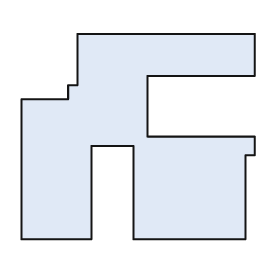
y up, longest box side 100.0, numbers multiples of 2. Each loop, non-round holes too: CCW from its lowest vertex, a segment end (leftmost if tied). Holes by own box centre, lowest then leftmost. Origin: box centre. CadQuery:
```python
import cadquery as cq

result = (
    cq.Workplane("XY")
    .moveTo(-50.0, -44.0)
    .lineTo(-20.0, -44.0)
    .lineTo(-20.0, -4.0)
    .lineTo(-2.0, -4.0)
    .lineTo(-2.0, -44.0)
    .lineTo(46.0, -44.0)
    .lineTo(46.0, -8.0)
    .lineTo(50.0, -8.0)
    .lineTo(50.0, 0.0)
    .lineTo(4.0, 0.0)
    .lineTo(4.0, 26.0)
    .lineTo(50.0, 26.0)
    .lineTo(50.0, 44.0)
    .lineTo(-26.0, 44.0)
    .lineTo(-26.0, 22.0)
    .lineTo(-30.0, 22.0)
    .lineTo(-30.0, 16.0)
    .lineTo(-50.0, 16.0)
    .close()
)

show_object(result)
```